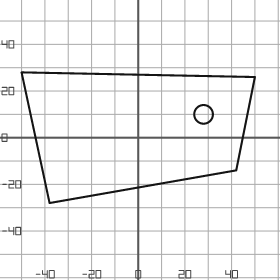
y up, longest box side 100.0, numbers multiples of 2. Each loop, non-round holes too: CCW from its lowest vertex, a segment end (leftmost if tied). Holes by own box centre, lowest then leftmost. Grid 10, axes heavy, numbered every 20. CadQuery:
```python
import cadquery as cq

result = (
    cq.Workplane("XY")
    .moveTo(-38.0, -28.0)
    .lineTo(42.0, -14.0)
    .lineTo(50.0, 26.0)
    .lineTo(-50.0, 28.0)
    .close()
    .moveTo(28.0, 10.0)
    .circle(4.0)
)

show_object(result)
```